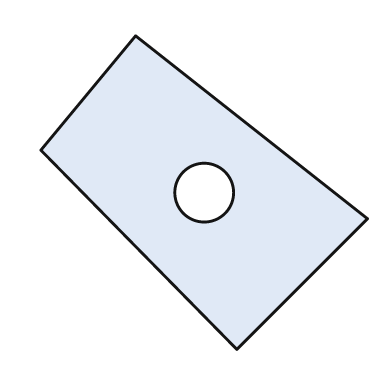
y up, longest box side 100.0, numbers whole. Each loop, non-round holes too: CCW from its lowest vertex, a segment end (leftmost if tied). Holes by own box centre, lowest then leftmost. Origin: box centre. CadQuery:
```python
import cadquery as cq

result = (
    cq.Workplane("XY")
    .moveTo(10.0, -48.0)
    .lineTo(50.0, -8.0)
    .lineTo(-21.0, 48.0)
    .lineTo(-50.0, 13.0)
    .close()
    .moveTo(0.0, 0.0)
    .circle(9.0)
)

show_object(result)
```